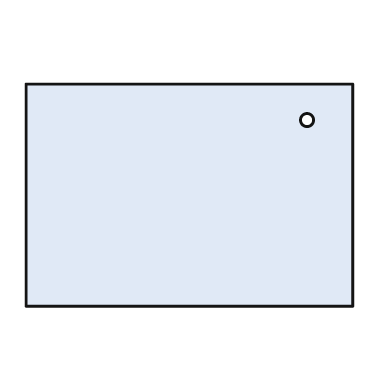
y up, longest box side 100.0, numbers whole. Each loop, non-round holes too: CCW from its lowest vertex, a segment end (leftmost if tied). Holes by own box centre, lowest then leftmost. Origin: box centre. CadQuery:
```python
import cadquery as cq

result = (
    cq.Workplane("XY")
    .moveTo(-50.0, -34.0)
    .lineTo(50.0, -34.0)
    .lineTo(50.0, 34.0)
    .lineTo(-50.0, 34.0)
    .close()
    .moveTo(36.0, 23.0)
    .circle(2.0)
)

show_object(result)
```